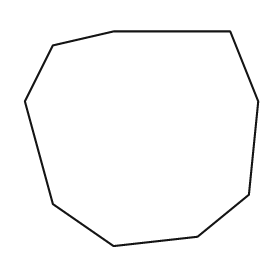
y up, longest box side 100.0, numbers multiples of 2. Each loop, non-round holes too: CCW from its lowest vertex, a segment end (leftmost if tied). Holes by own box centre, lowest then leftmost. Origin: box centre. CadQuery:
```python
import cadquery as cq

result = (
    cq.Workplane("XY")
    .moveTo(-12.0, -46.0)
    .lineTo(24.0, -42.0)
    .lineTo(46.0, -24.0)
    .lineTo(50.0, 16.0)
    .lineTo(38.0, 46.0)
    .lineTo(-12.0, 46.0)
    .lineTo(-38.0, 40.0)
    .lineTo(-50.0, 16.0)
    .lineTo(-38.0, -28.0)
    .close()
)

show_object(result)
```